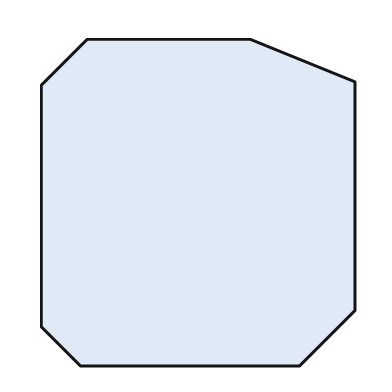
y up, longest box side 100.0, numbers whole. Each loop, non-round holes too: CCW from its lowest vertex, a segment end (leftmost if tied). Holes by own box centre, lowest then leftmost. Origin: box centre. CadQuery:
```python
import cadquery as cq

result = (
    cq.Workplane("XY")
    .moveTo(-36.0, -50.0)
    .lineTo(31.0, -50.0)
    .lineTo(48.0, -33.0)
    .lineTo(48.0, 37.0)
    .lineTo(16.0, 50.0)
    .lineTo(-34.0, 50.0)
    .lineTo(-48.0, 36.0)
    .lineTo(-48.0, -38.0)
    .close()
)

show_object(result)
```